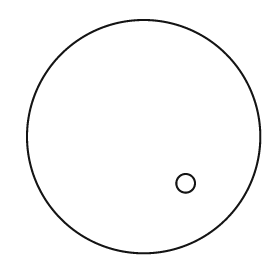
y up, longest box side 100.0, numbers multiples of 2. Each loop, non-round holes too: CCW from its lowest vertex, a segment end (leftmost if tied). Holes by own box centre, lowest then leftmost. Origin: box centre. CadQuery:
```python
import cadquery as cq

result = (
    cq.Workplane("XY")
    .moveTo(0.0, 0.0)
    .circle(50.0)
    .moveTo(18.0, -20.0)
    .circle(4.0)
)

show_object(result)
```